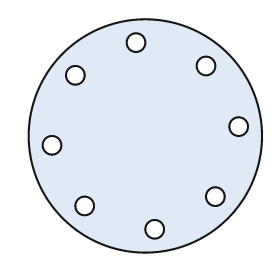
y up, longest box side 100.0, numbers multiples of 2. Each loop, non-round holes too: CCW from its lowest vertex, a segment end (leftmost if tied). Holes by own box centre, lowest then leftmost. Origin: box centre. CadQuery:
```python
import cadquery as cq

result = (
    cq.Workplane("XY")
    .moveTo(0.0, 0.0)
    .circle(50.0)
    .moveTo(4.0, -40.0)
    .circle(4.0)
    .moveTo(-26.0, -30.0)
    .circle(4.0)
    .moveTo(30.0, -26.0)
    .circle(4.0)
    .moveTo(-40.0, -4.0)
    .circle(4.0)
    .moveTo(40.0, 4.0)
    .circle(4.0)
    .moveTo(-30.0, 26.0)
    .circle(4.0)
    .moveTo(26.0, 30.0)
    .circle(4.0)
    .moveTo(-4.0, 40.0)
    .circle(4.0)
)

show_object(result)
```